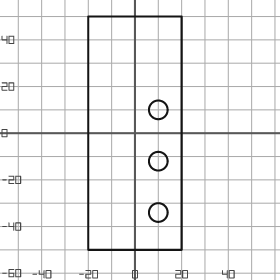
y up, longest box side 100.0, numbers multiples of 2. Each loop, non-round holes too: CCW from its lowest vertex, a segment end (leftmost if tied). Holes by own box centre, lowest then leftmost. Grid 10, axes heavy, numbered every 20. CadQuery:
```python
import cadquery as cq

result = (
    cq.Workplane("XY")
    .moveTo(-20.0, -50.0)
    .lineTo(20.0, -50.0)
    .lineTo(20.0, 50.0)
    .lineTo(-20.0, 50.0)
    .close()
    .moveTo(10.0, -34.0)
    .circle(4.0)
    .moveTo(10.0, -12.0)
    .circle(4.0)
    .moveTo(10.0, 10.0)
    .circle(4.0)
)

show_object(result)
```